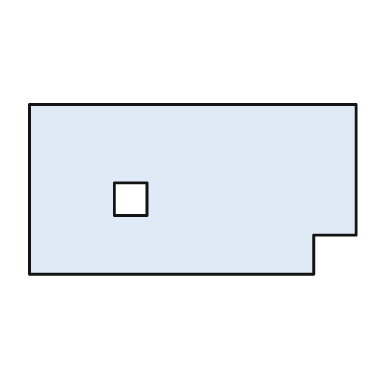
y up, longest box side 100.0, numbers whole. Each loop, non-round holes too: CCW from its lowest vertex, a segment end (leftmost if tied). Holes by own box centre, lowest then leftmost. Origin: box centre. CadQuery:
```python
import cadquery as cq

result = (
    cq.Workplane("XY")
    .moveTo(-50.0, -26.0)
    .lineTo(37.0, -26.0)
    .lineTo(37.0, -14.0)
    .lineTo(50.0, -14.0)
    .lineTo(50.0, 26.0)
    .lineTo(-50.0, 26.0)
    .close()
    .moveTo(-24.0, -8.0)
    .lineTo(-14.0, -8.0)
    .lineTo(-14.0, 2.0)
    .lineTo(-24.0, 2.0)
    .close()
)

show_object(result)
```